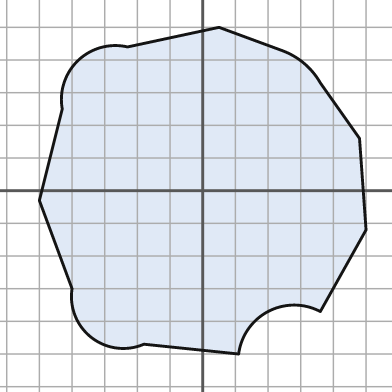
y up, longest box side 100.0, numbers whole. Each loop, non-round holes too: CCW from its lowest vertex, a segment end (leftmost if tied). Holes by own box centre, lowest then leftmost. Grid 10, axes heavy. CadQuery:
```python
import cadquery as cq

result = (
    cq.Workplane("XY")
    .moveTo(11.0, -50.0)
    .threePointArc((20.0, -37.0), (36.0, -37.0))
    .lineTo(50.0, -12.0)
    .lineTo(48.0, 16.0)
    .lineTo(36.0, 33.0)
    .threePointArc((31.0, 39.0), (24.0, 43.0))
    .lineTo(5.0, 50.0)
    .lineTo(-23.0, 44.0)
    .threePointArc((-38.0, 40.0), (-43.0, 25.0))
    .lineTo(-50.0, -3.0)
    .lineTo(-40.0, -30.0)
    .threePointArc((-34.0, -45.0), (-18.0, -47.0))
    .close()
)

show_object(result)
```